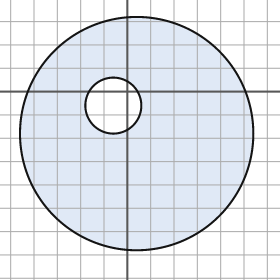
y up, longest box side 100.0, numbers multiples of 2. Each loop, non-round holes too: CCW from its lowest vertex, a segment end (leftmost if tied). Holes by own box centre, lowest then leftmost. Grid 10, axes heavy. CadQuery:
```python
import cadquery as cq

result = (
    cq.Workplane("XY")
    .moveTo(4.0, -18.0)
    .circle(50.0)
    .moveTo(-6.0, -6.0)
    .circle(12.0)
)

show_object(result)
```